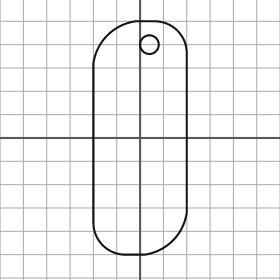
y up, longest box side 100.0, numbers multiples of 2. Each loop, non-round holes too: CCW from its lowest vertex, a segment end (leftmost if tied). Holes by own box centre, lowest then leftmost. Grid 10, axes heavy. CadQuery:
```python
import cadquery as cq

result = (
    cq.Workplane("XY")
    .moveTo(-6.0, -50.0)
    .lineTo(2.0, -50.0)
    .threePointArc((14.0, -44.0), (20.0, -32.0))
    .lineTo(20.0, 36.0)
    .threePointArc((16.0, 46.0), (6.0, 50.0))
    .lineTo(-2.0, 50.0)
    .threePointArc((-14.0, 44.0), (-20.0, 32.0))
    .lineTo(-20.0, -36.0)
    .threePointArc((-16.0, -46.0), (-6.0, -50.0))
    .close()
    .moveTo(4.0, 40.0)
    .circle(4.0)
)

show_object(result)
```